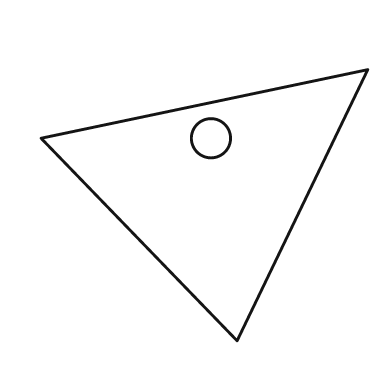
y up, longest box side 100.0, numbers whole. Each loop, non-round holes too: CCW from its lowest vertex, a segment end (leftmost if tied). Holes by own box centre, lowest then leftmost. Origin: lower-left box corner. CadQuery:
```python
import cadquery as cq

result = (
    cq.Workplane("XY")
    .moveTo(60.0, 0.0)
    .lineTo(100.0, 83.0)
    .lineTo(0.0, 62.0)
    .close()
    .moveTo(52.0, 62.0)
    .circle(6.0)
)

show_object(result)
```